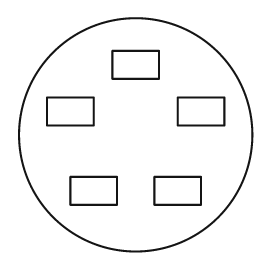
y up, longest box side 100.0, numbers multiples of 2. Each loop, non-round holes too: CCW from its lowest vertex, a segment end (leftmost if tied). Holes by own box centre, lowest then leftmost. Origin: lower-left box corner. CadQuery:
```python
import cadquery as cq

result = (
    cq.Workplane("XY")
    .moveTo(50.0, 50.0)
    .circle(50.0)
    .moveTo(22.0, 20.0)
    .lineTo(42.0, 20.0)
    .lineTo(42.0, 32.0)
    .lineTo(22.0, 32.0)
    .close()
    .moveTo(58.0, 20.0)
    .lineTo(78.0, 20.0)
    .lineTo(78.0, 32.0)
    .lineTo(58.0, 32.0)
    .close()
    .moveTo(12.0, 54.0)
    .lineTo(32.0, 54.0)
    .lineTo(32.0, 66.0)
    .lineTo(12.0, 66.0)
    .close()
    .moveTo(68.0, 54.0)
    .lineTo(88.0, 54.0)
    .lineTo(88.0, 66.0)
    .lineTo(68.0, 66.0)
    .close()
    .moveTo(40.0, 74.0)
    .lineTo(60.0, 74.0)
    .lineTo(60.0, 86.0)
    .lineTo(40.0, 86.0)
    .close()
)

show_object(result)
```